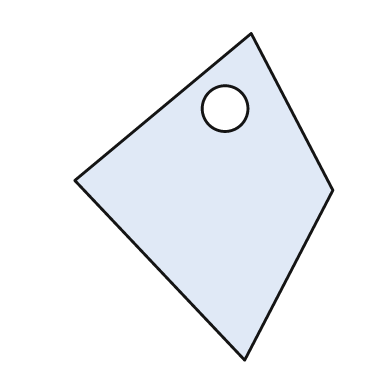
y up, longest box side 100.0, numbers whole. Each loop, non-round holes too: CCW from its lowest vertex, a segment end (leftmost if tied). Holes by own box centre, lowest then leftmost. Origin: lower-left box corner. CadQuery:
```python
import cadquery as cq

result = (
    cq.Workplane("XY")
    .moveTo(52.0, 0.0)
    .lineTo(79.0, 52.0)
    .lineTo(54.0, 100.0)
    .lineTo(0.0, 55.0)
    .close()
    .moveTo(46.0, 77.0)
    .circle(7.0)
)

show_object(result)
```